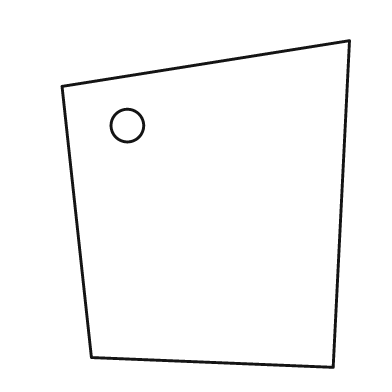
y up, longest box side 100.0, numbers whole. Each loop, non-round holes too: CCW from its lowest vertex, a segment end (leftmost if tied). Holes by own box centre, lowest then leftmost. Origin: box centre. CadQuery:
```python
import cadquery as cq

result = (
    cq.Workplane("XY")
    .moveTo(39.0, -50.0)
    .lineTo(44.0, 50.0)
    .lineTo(-44.0, 36.0)
    .lineTo(-35.0, -47.0)
    .close()
    .moveTo(-24.0, 24.0)
    .circle(5.0)
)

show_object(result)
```